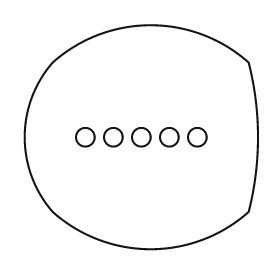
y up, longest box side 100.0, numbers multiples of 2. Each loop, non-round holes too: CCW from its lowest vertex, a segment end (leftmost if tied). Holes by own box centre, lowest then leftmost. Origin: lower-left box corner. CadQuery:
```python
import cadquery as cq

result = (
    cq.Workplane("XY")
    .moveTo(12.0, 16.0)
    .threePointArc((54.0, 0.0), (96.0, 16.0))
    .threePointArc((100.0, 48.0), (96.0, 80.0))
    .threePointArc((54.0, 96.0), (12.0, 80.0))
    .threePointArc((0.0, 48.0), (12.0, 16.0))
    .close()
    .moveTo(26.0, 48.0)
    .circle(4.0)
    .moveTo(38.0, 48.0)
    .circle(4.0)
    .moveTo(50.0, 48.0)
    .circle(4.0)
    .moveTo(62.0, 48.0)
    .circle(4.0)
    .moveTo(74.0, 48.0)
    .circle(4.0)
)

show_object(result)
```